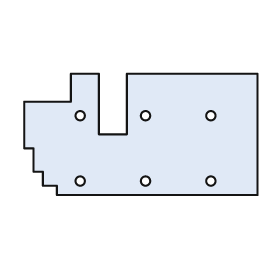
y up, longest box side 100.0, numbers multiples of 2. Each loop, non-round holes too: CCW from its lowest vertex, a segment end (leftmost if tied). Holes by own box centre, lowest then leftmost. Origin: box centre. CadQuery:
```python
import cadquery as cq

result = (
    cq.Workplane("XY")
    .moveTo(-36.0, -26.0)
    .lineTo(50.0, -26.0)
    .lineTo(50.0, 26.0)
    .lineTo(-6.0, 26.0)
    .lineTo(-6.0, 0.0)
    .lineTo(-18.0, 0.0)
    .lineTo(-18.0, 26.0)
    .lineTo(-30.0, 26.0)
    .lineTo(-30.0, 14.0)
    .lineTo(-50.0, 14.0)
    .lineTo(-50.0, -6.0)
    .lineTo(-46.0, -6.0)
    .lineTo(-46.0, -16.0)
    .lineTo(-42.0, -16.0)
    .lineTo(-42.0, -22.0)
    .lineTo(-36.0, -22.0)
    .close()
    .moveTo(-26.0, -20.0)
    .circle(2.0)
    .moveTo(2.0, -20.0)
    .circle(2.0)
    .moveTo(30.0, -20.0)
    .circle(2.0)
    .moveTo(-26.0, 8.0)
    .circle(2.0)
    .moveTo(2.0, 8.0)
    .circle(2.0)
    .moveTo(30.0, 8.0)
    .circle(2.0)
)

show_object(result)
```